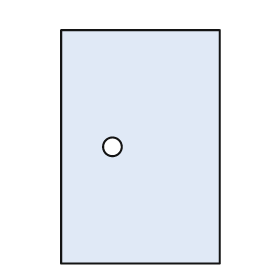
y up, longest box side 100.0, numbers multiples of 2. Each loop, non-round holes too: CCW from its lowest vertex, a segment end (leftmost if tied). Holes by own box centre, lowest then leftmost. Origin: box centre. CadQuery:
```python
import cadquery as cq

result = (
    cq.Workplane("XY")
    .moveTo(-34.0, -50.0)
    .lineTo(34.0, -50.0)
    .lineTo(34.0, 50.0)
    .lineTo(-34.0, 50.0)
    .close()
    .moveTo(-12.0, 0.0)
    .circle(4.0)
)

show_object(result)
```